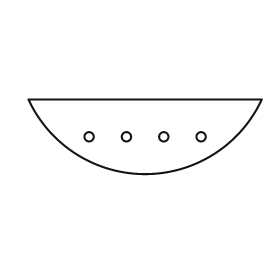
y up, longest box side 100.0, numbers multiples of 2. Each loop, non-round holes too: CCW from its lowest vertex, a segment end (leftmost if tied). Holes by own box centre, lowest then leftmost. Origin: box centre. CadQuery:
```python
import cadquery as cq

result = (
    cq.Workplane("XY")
    .moveTo(-50.0, 16.0)
    .threePointArc((0.0, -16.0), (50.0, 16.0))
    .close()
    .moveTo(-24.0, 0.0)
    .circle(2.0)
    .moveTo(-8.0, 0.0)
    .circle(2.0)
    .moveTo(8.0, 0.0)
    .circle(2.0)
    .moveTo(24.0, 0.0)
    .circle(2.0)
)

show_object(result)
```